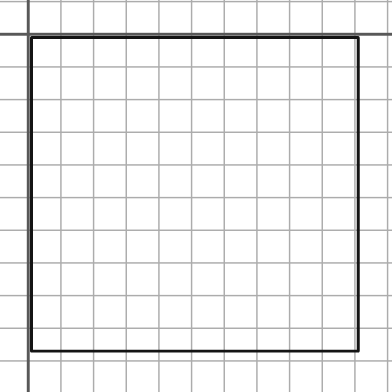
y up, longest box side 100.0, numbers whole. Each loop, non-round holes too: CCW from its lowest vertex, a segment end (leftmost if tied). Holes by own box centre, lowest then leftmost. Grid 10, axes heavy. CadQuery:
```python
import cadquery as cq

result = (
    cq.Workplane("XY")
    .moveTo(1.0, -97.0)
    .lineTo(101.0, -97.0)
    .lineTo(101.0, -1.0)
    .lineTo(1.0, -1.0)
    .close()
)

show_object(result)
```